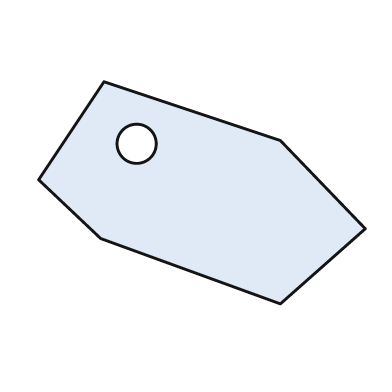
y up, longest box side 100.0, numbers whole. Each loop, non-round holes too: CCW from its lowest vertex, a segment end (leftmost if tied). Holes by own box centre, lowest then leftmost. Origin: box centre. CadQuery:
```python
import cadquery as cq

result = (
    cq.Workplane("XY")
    .moveTo(24.0, -34.0)
    .lineTo(50.0, -11.0)
    .lineTo(24.0, 16.0)
    .lineTo(-30.0, 34.0)
    .lineTo(-50.0, 4.0)
    .lineTo(-31.0, -14.0)
    .close()
    .moveTo(-20.0, 15.0)
    .circle(6.0)
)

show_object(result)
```